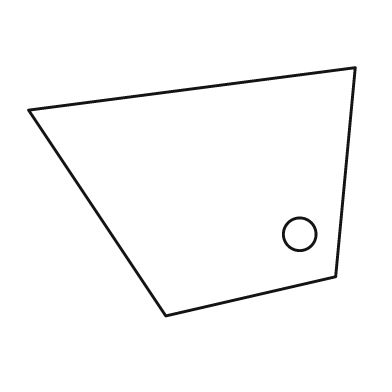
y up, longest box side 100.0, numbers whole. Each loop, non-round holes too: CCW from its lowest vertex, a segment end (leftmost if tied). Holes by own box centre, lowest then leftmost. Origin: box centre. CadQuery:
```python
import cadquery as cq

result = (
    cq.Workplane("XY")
    .moveTo(-8.0, -38.0)
    .lineTo(44.0, -26.0)
    .lineTo(50.0, 38.0)
    .lineTo(-50.0, 25.0)
    .close()
    .moveTo(33.0, -13.0)
    .circle(5.0)
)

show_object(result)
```